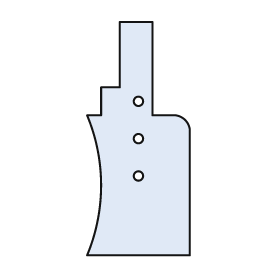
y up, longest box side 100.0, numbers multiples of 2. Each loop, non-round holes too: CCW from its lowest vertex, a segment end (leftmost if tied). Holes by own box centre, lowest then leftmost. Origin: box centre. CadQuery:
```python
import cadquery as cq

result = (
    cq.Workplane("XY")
    .moveTo(-22.0, -50.0)
    .lineTo(22.0, -50.0)
    .lineTo(22.0, 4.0)
    .threePointArc((20.0, 8.0), (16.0, 10.0))
    .lineTo(6.0, 10.0)
    .lineTo(6.0, 50.0)
    .lineTo(-8.0, 50.0)
    .lineTo(-8.0, 22.0)
    .lineTo(-16.0, 22.0)
    .lineTo(-16.0, 10.0)
    .lineTo(-22.0, 10.0)
    .threePointArc((-16.0, -20.0), (-22.0, -50.0))
    .close()
    .moveTo(0.0, -16.0)
    .circle(2.0)
    .moveTo(0.0, 0.0)
    .circle(2.0)
    .moveTo(0.0, 16.0)
    .circle(2.0)
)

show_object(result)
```